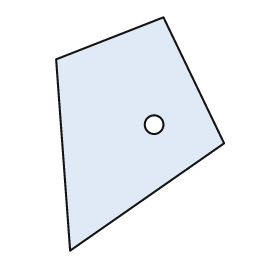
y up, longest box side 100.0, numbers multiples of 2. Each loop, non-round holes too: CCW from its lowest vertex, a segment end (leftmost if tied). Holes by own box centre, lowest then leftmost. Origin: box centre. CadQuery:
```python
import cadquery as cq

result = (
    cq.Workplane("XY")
    .moveTo(-30.0, -50.0)
    .lineTo(36.0, -4.0)
    .lineTo(10.0, 50.0)
    .lineTo(-36.0, 32.0)
    .close()
    .moveTo(6.0, 4.0)
    .circle(4.0)
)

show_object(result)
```